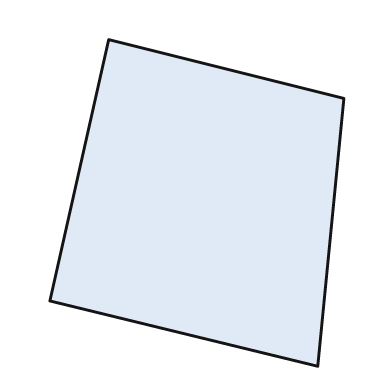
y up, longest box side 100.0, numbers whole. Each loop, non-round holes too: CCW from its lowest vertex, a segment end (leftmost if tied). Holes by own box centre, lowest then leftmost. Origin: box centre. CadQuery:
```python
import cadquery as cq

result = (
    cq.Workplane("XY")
    .moveTo(37.0, -50.0)
    .lineTo(45.0, 32.0)
    .lineTo(-27.0, 50.0)
    .lineTo(-45.0, -30.0)
    .close()
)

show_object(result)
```